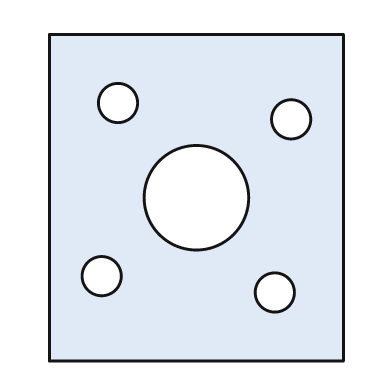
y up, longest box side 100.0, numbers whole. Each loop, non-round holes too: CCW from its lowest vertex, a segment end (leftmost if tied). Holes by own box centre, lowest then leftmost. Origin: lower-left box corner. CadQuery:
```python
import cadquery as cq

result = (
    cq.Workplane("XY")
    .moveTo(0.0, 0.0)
    .lineTo(90.0, 0.0)
    .lineTo(90.0, 100.0)
    .lineTo(0.0, 100.0)
    .close()
    .moveTo(69.0, 21.0)
    .circle(6.0)
    .moveTo(16.0, 26.0)
    .circle(6.0)
    .moveTo(45.0, 50.0)
    .circle(16.0)
    .moveTo(74.0, 74.0)
    .circle(6.0)
    .moveTo(21.0, 79.0)
    .circle(6.0)
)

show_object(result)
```